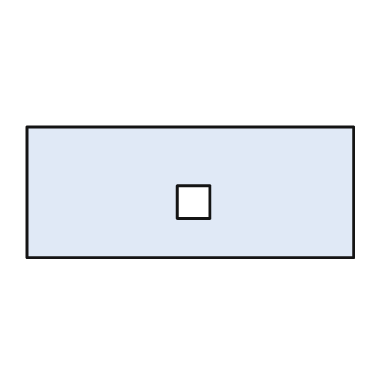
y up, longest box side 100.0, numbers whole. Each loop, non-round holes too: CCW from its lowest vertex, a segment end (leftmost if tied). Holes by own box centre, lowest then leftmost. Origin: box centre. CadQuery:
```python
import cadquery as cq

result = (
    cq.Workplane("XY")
    .moveTo(-50.0, -20.0)
    .lineTo(50.0, -20.0)
    .lineTo(50.0, 20.0)
    .lineTo(-50.0, 20.0)
    .close()
    .moveTo(-4.0, -8.0)
    .lineTo(6.0, -8.0)
    .lineTo(6.0, 2.0)
    .lineTo(-4.0, 2.0)
    .close()
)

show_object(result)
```